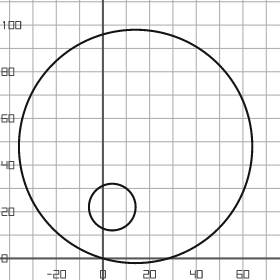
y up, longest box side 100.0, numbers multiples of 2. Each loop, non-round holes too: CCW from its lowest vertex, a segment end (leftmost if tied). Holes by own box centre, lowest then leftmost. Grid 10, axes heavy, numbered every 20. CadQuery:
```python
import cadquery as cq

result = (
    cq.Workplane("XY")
    .moveTo(14.0, 48.0)
    .circle(50.0)
    .moveTo(4.0, 22.0)
    .circle(10.0)
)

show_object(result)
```